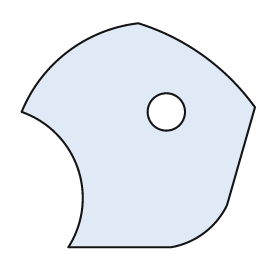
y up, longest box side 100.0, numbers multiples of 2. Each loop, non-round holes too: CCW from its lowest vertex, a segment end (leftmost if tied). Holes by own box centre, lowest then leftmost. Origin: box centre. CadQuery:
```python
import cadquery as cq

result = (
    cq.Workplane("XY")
    .moveTo(-30.0, -48.0)
    .lineTo(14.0, -48.0)
    .threePointArc((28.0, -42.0), (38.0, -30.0))
    .lineTo(50.0, 12.0)
    .threePointArc((28.0, 34.0), (0.0, 48.0))
    .threePointArc((-30.0, 36.0), (-50.0, 10.0))
    .threePointArc((-26.0, -14.0), (-30.0, -48.0))
    .close()
    .moveTo(12.0, 10.0)
    .circle(8.0)
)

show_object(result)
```